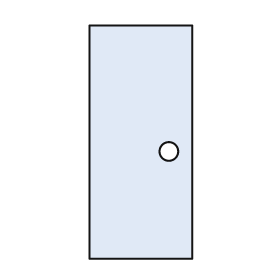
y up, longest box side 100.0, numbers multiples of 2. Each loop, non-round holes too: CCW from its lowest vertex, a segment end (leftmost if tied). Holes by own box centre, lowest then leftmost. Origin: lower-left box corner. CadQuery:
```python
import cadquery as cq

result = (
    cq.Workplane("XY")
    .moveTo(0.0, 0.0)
    .lineTo(44.0, 0.0)
    .lineTo(44.0, 100.0)
    .lineTo(0.0, 100.0)
    .close()
    .moveTo(34.0, 46.0)
    .circle(4.0)
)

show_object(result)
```